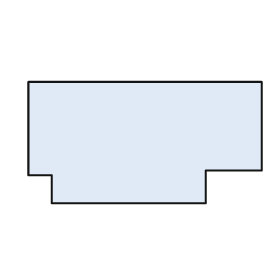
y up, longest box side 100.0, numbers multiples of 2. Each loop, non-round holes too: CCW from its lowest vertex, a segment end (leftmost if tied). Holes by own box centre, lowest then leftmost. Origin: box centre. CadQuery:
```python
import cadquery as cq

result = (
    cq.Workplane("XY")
    .moveTo(-40.0, -26.0)
    .lineTo(26.0, -26.0)
    .lineTo(26.0, -12.0)
    .lineTo(50.0, -12.0)
    .lineTo(50.0, 26.0)
    .lineTo(-50.0, 26.0)
    .lineTo(-50.0, -14.0)
    .lineTo(-40.0, -14.0)
    .close()
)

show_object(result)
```